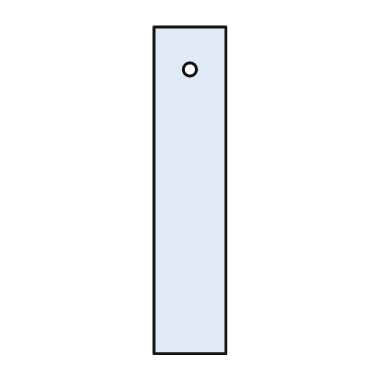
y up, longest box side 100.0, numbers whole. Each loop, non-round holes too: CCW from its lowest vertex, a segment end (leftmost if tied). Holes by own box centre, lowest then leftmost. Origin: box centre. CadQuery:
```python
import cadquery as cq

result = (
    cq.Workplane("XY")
    .moveTo(-11.0, -50.0)
    .lineTo(11.0, -50.0)
    .lineTo(11.0, 50.0)
    .lineTo(-11.0, 50.0)
    .close()
    .moveTo(0.0, 37.0)
    .circle(2.0)
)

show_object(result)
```